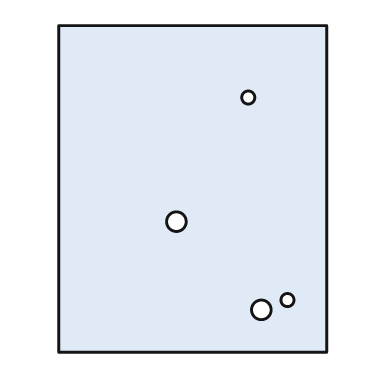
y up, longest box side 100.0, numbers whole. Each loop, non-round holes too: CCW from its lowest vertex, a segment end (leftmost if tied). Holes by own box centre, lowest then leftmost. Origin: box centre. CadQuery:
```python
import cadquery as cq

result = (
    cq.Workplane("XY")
    .moveTo(-41.0, -50.0)
    .lineTo(41.0, -50.0)
    .lineTo(41.0, 50.0)
    .lineTo(-41.0, 50.0)
    .close()
    .moveTo(21.0, -37.0)
    .circle(3.0)
    .moveTo(29.0, -34.0)
    .circle(2.0)
    .moveTo(-5.0, -10.0)
    .circle(3.0)
    .moveTo(17.0, 28.0)
    .circle(2.0)
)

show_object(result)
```